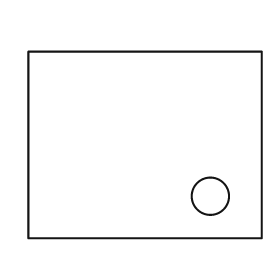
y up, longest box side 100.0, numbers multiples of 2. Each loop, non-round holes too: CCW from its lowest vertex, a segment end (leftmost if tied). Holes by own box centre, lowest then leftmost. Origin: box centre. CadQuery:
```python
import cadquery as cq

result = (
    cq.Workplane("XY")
    .moveTo(-50.0, -40.0)
    .lineTo(50.0, -40.0)
    .lineTo(50.0, 40.0)
    .lineTo(-50.0, 40.0)
    .close()
    .moveTo(28.0, -22.0)
    .circle(8.0)
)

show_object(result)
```